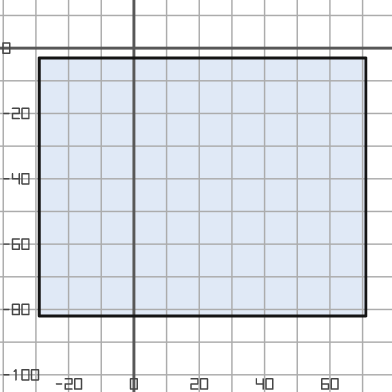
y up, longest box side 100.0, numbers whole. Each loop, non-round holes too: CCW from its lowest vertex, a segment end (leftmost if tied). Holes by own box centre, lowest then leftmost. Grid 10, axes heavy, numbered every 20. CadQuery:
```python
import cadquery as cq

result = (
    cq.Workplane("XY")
    .moveTo(-29.0, -82.0)
    .lineTo(71.0, -82.0)
    .lineTo(71.0, -3.0)
    .lineTo(-29.0, -3.0)
    .close()
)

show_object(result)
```